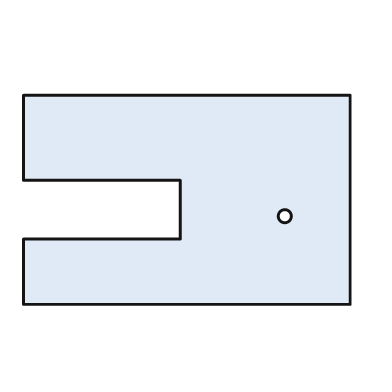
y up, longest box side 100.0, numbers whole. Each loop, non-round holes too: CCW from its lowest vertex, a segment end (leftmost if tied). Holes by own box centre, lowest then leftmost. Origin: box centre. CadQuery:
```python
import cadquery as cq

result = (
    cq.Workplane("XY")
    .moveTo(-50.0, -32.0)
    .lineTo(50.0, -32.0)
    .lineTo(50.0, 32.0)
    .lineTo(-50.0, 32.0)
    .lineTo(-50.0, 6.0)
    .lineTo(-2.0, 6.0)
    .lineTo(-2.0, -12.0)
    .lineTo(-50.0, -12.0)
    .close()
    .moveTo(30.0, -5.0)
    .circle(2.0)
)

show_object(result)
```